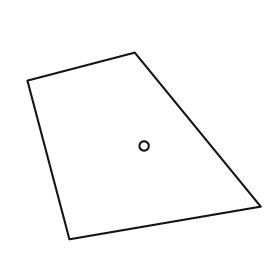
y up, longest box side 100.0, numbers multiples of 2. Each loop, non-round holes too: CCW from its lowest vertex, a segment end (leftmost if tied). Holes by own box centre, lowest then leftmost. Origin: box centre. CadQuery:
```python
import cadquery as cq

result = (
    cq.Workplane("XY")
    .moveTo(-32.0, -40.0)
    .lineTo(50.0, -26.0)
    .lineTo(-4.0, 40.0)
    .lineTo(-50.0, 28.0)
    .close()
    .moveTo(0.0, 0.0)
    .circle(2.0)
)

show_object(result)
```